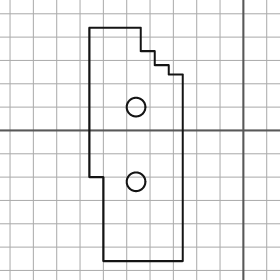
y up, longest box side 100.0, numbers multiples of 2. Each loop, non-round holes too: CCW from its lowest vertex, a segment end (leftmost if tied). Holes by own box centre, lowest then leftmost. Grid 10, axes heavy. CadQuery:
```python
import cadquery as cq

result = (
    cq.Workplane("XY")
    .moveTo(-60.0, -56.0)
    .lineTo(-26.0, -56.0)
    .lineTo(-26.0, 24.0)
    .lineTo(-32.0, 24.0)
    .lineTo(-32.0, 28.0)
    .lineTo(-38.0, 28.0)
    .lineTo(-38.0, 34.0)
    .lineTo(-44.0, 34.0)
    .lineTo(-44.0, 44.0)
    .lineTo(-66.0, 44.0)
    .lineTo(-66.0, -20.0)
    .lineTo(-60.0, -20.0)
    .close()
    .moveTo(-46.0, -22.0)
    .circle(4.0)
    .moveTo(-46.0, 10.0)
    .circle(4.0)
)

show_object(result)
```